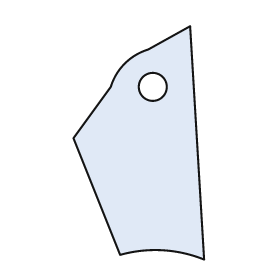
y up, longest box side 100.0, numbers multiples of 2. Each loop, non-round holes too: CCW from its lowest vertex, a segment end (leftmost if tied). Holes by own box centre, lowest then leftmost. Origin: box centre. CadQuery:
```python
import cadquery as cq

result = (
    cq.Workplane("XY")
    .moveTo(28.0, -50.0)
    .lineTo(22.0, 50.0)
    .lineTo(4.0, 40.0)
    .threePointArc((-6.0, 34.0), (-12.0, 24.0))
    .lineTo(-28.0, 2.0)
    .lineTo(-8.0, -48.0)
    .threePointArc((10.0, -46.0), (28.0, -50.0))
    .close()
    .moveTo(6.0, 24.0)
    .circle(6.0)
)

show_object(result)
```